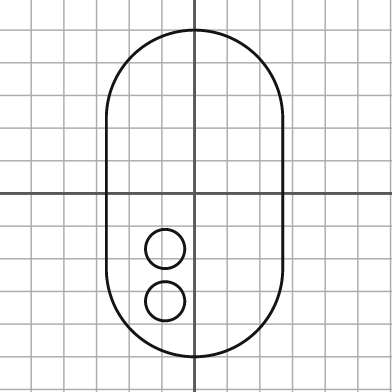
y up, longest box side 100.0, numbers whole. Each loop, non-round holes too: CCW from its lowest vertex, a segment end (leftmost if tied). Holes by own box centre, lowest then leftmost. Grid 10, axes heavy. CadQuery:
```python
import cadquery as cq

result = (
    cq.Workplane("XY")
    .moveTo(-27.0, -23.0)
    .threePointArc((0.0, -50.0), (27.0, -23.0))
    .lineTo(27.0, 23.0)
    .threePointArc((0.0, 50.0), (-27.0, 23.0))
    .close()
    .moveTo(-9.0, -33.0)
    .circle(6.0)
    .moveTo(-9.0, -17.0)
    .circle(6.0)
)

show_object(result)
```